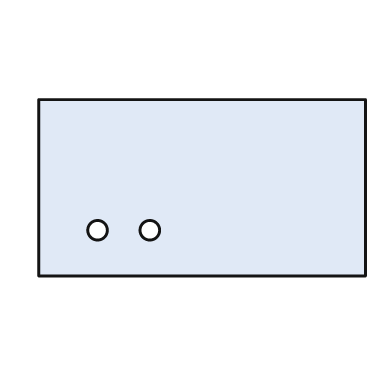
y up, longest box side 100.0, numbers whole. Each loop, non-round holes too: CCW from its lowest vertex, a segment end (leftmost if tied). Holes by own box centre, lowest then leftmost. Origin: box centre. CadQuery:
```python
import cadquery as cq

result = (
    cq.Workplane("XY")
    .moveTo(-50.0, -27.0)
    .lineTo(50.0, -27.0)
    .lineTo(50.0, 27.0)
    .lineTo(-50.0, 27.0)
    .close()
    .moveTo(-32.0, -13.0)
    .circle(3.0)
    .moveTo(-16.0, -13.0)
    .circle(3.0)
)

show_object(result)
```